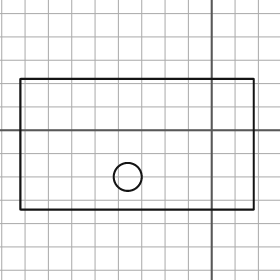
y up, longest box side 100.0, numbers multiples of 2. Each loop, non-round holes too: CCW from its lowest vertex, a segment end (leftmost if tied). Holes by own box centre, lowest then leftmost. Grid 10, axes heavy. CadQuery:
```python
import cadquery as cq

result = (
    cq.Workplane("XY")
    .moveTo(-82.0, -34.0)
    .lineTo(18.0, -34.0)
    .lineTo(18.0, 22.0)
    .lineTo(-82.0, 22.0)
    .close()
    .moveTo(-36.0, -20.0)
    .circle(6.0)
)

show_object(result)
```